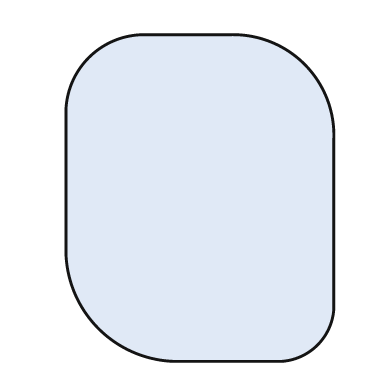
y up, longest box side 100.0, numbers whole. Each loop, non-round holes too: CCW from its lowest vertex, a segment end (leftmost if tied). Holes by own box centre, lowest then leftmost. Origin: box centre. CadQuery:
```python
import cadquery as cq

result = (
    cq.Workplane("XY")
    .moveTo(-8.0, -50.0)
    .lineTo(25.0, -50.0)
    .threePointArc((36.0, -45.0), (41.0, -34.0))
    .lineTo(41.0, 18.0)
    .threePointArc((32.0, 41.0), (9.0, 50.0))
    .lineTo(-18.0, 50.0)
    .threePointArc((-34.0, 43.0), (-41.0, 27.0))
    .lineTo(-41.0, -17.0)
    .threePointArc((-31.0, -40.0), (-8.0, -50.0))
    .close()
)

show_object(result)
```